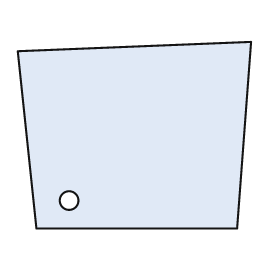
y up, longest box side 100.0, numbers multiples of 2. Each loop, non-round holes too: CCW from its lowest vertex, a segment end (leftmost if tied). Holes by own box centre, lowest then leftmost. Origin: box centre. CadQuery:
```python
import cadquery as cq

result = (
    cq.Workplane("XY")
    .moveTo(-42.0, -40.0)
    .lineTo(44.0, -40.0)
    .lineTo(50.0, 40.0)
    .lineTo(-50.0, 36.0)
    .close()
    .moveTo(-28.0, -28.0)
    .circle(4.0)
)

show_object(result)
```